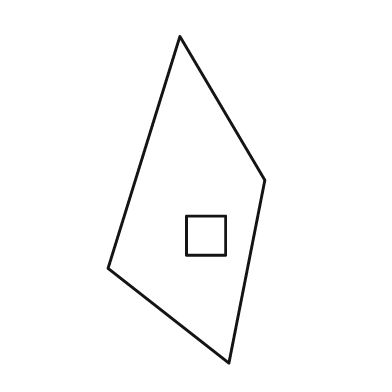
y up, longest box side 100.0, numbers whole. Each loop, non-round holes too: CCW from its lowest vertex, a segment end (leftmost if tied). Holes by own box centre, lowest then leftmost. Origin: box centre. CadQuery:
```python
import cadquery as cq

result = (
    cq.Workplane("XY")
    .moveTo(13.0, -50.0)
    .lineTo(24.0, 6.0)
    .lineTo(-2.0, 50.0)
    .lineTo(-24.0, -21.0)
    .close()
    .moveTo(0.0, -17.0)
    .lineTo(12.0, -17.0)
    .lineTo(12.0, -5.0)
    .lineTo(0.0, -5.0)
    .close()
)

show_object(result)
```